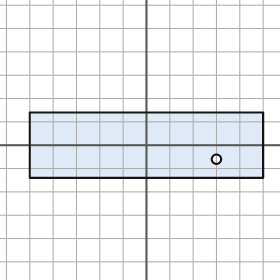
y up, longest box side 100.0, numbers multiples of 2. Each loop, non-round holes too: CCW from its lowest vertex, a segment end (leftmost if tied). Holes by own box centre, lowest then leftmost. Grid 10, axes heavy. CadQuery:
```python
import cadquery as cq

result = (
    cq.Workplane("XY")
    .moveTo(-50.0, -14.0)
    .lineTo(50.0, -14.0)
    .lineTo(50.0, 14.0)
    .lineTo(-50.0, 14.0)
    .close()
    .moveTo(30.0, -6.0)
    .circle(2.0)
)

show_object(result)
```